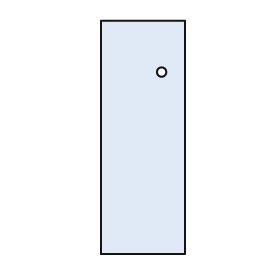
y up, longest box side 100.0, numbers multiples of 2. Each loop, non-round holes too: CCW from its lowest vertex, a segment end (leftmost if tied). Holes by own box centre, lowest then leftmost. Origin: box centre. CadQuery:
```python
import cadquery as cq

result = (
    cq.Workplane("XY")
    .moveTo(-18.0, -50.0)
    .lineTo(18.0, -50.0)
    .lineTo(18.0, 50.0)
    .lineTo(-18.0, 50.0)
    .close()
    .moveTo(8.0, 28.0)
    .circle(2.0)
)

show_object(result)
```